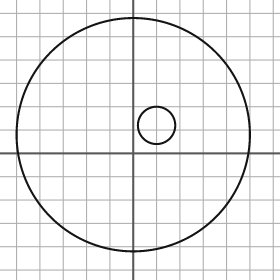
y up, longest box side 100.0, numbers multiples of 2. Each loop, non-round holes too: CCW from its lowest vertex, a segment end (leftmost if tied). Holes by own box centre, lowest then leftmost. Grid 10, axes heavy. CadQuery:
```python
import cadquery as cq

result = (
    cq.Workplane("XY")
    .moveTo(0.0, 8.0)
    .circle(50.0)
    .moveTo(10.0, 12.0)
    .circle(8.0)
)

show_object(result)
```